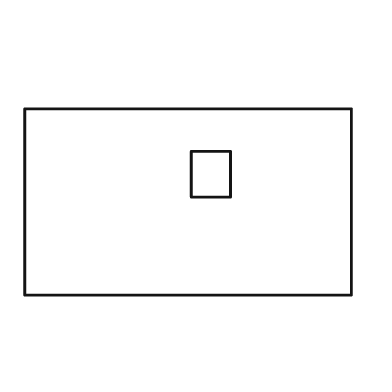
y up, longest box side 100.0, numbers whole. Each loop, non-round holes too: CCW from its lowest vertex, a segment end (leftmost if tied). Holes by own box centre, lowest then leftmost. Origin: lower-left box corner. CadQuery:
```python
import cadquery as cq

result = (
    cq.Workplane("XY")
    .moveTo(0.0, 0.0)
    .lineTo(100.0, 0.0)
    .lineTo(100.0, 57.0)
    .lineTo(0.0, 57.0)
    .close()
    .moveTo(51.0, 30.0)
    .lineTo(63.0, 30.0)
    .lineTo(63.0, 44.0)
    .lineTo(51.0, 44.0)
    .close()
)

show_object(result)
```